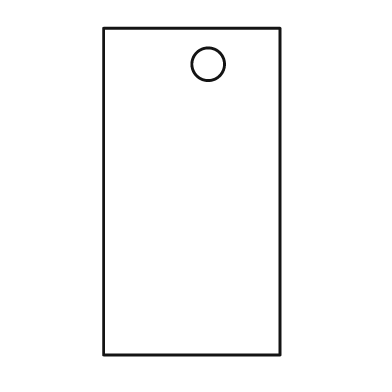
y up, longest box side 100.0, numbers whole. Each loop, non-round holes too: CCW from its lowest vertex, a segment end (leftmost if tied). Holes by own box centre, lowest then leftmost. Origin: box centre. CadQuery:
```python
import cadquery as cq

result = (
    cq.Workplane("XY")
    .moveTo(-27.0, -50.0)
    .lineTo(27.0, -50.0)
    .lineTo(27.0, 50.0)
    .lineTo(-27.0, 50.0)
    .close()
    .moveTo(5.0, 39.0)
    .circle(5.0)
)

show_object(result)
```